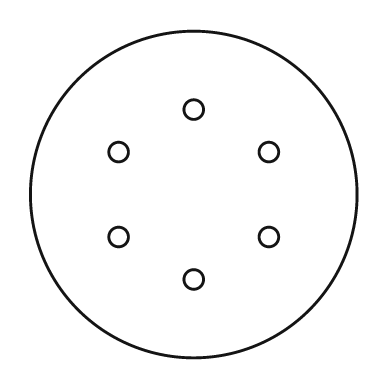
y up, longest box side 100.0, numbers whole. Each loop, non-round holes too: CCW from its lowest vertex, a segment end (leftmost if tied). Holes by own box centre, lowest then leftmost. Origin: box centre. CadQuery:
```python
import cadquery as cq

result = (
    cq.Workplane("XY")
    .moveTo(0.0, 0.0)
    .circle(50.0)
    .moveTo(0.0, -26.0)
    .circle(3.0)
    .moveTo(-23.0, -13.0)
    .circle(3.0)
    .moveTo(23.0, -13.0)
    .circle(3.0)
    .moveTo(-23.0, 13.0)
    .circle(3.0)
    .moveTo(23.0, 13.0)
    .circle(3.0)
    .moveTo(0.0, 26.0)
    .circle(3.0)
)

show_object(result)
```